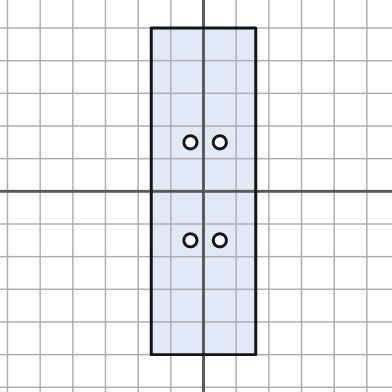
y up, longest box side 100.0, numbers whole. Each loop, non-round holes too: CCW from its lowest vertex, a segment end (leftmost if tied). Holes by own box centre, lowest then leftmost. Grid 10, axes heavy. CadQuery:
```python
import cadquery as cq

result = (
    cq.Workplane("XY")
    .moveTo(-16.0, -50.0)
    .lineTo(16.0, -50.0)
    .lineTo(16.0, 50.0)
    .lineTo(-16.0, 50.0)
    .close()
    .moveTo(-4.0, -15.0)
    .circle(2.0)
    .moveTo(5.0, -15.0)
    .circle(2.0)
    .moveTo(-4.0, 15.0)
    .circle(2.0)
    .moveTo(5.0, 15.0)
    .circle(2.0)
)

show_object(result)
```